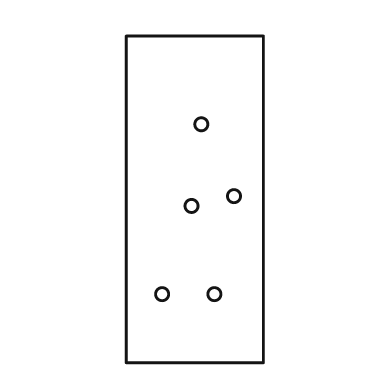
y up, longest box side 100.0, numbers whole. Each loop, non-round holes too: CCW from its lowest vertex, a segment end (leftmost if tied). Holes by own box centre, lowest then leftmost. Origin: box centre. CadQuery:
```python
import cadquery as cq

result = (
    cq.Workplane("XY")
    .moveTo(-21.0, -50.0)
    .lineTo(21.0, -50.0)
    .lineTo(21.0, 50.0)
    .lineTo(-21.0, 50.0)
    .close()
    .moveTo(-10.0, -29.0)
    .circle(2.0)
    .moveTo(6.0, -29.0)
    .circle(2.0)
    .moveTo(-1.0, -2.0)
    .circle(2.0)
    .moveTo(12.0, 1.0)
    .circle(2.0)
    .moveTo(2.0, 23.0)
    .circle(2.0)
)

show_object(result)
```